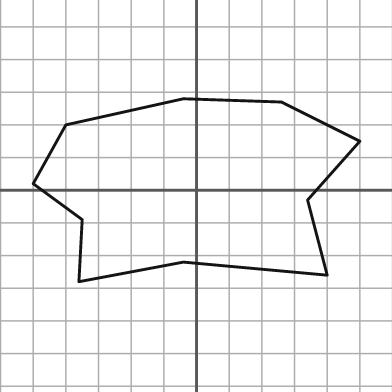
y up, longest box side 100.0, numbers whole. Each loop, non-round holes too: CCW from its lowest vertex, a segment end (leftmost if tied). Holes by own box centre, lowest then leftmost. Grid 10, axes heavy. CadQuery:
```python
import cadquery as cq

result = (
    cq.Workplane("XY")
    .moveTo(-36.0, -28.0)
    .lineTo(-4.0, -22.0)
    .lineTo(40.0, -26.0)
    .lineTo(34.0, -3.0)
    .lineTo(50.0, 15.0)
    .lineTo(26.0, 27.0)
    .lineTo(-4.0, 28.0)
    .lineTo(-40.0, 20.0)
    .lineTo(-50.0, 2.0)
    .lineTo(-35.0, -9.0)
    .close()
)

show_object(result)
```